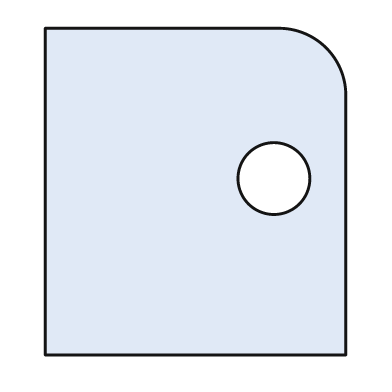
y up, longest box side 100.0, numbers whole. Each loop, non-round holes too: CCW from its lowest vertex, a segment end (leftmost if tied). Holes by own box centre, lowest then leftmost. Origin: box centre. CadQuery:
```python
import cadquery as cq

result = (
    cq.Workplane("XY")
    .moveTo(-46.0, -50.0)
    .lineTo(46.0, -50.0)
    .lineTo(46.0, 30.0)
    .threePointArc((40.0, 44.0), (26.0, 50.0))
    .lineTo(-46.0, 50.0)
    .close()
    .moveTo(24.0, 4.0)
    .circle(11.0)
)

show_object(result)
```